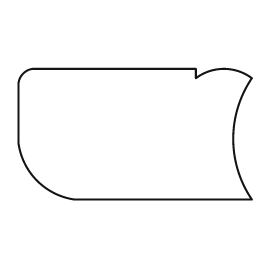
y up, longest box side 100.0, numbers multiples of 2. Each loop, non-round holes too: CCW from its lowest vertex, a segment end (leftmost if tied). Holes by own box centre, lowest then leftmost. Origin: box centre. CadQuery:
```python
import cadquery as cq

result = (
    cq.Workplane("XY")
    .moveTo(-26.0, -28.0)
    .lineTo(50.0, -28.0)
    .threePointArc((42.0, -2.0), (50.0, 24.0))
    .threePointArc((38.0, 28.0), (26.0, 24.0))
    .lineTo(26.0, 28.0)
    .lineTo(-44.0, 28.0)
    .threePointArc((-48.0, 26.0), (-50.0, 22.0))
    .lineTo(-50.0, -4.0)
    .threePointArc((-42.0, -20.0), (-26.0, -28.0))
    .close()
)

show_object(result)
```